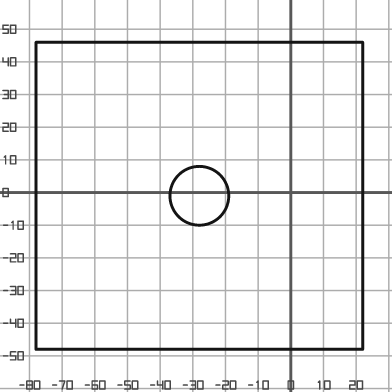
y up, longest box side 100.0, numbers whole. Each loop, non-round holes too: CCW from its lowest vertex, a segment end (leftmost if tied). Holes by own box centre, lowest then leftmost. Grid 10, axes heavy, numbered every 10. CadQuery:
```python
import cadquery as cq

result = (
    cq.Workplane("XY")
    .moveTo(-78.0, -48.0)
    .lineTo(22.0, -48.0)
    .lineTo(22.0, 46.0)
    .lineTo(-78.0, 46.0)
    .close()
    .moveTo(-28.0, -1.0)
    .circle(9.0)
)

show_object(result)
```